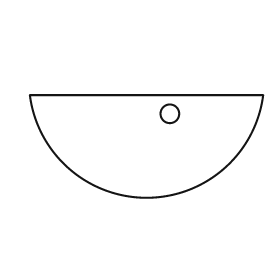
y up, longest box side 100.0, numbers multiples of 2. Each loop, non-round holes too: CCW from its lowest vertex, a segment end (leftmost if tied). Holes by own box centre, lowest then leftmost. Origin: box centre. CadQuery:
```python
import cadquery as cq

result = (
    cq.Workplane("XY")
    .moveTo(-50.0, 22.0)
    .threePointArc((0.0, -22.0), (50.0, 22.0))
    .close()
    .moveTo(10.0, 14.0)
    .circle(4.0)
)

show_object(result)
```